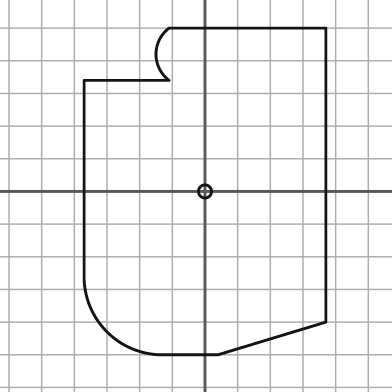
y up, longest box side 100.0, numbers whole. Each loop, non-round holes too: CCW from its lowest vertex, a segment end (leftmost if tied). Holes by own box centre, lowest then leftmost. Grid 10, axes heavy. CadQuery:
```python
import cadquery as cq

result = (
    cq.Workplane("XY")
    .moveTo(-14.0, -50.0)
    .lineTo(4.0, -50.0)
    .lineTo(37.0, -40.0)
    .lineTo(37.0, 50.0)
    .lineTo(-11.0, 50.0)
    .threePointArc((-15.0, 42.0), (-11.0, 34.0))
    .lineTo(-37.0, 34.0)
    .lineTo(-37.0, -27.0)
    .threePointArc((-30.0, -43.0), (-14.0, -50.0))
    .close()
    .moveTo(0.0, 0.0)
    .circle(2.0)
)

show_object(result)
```